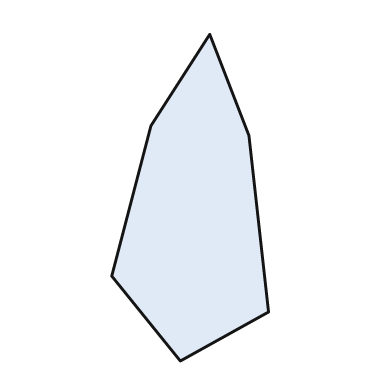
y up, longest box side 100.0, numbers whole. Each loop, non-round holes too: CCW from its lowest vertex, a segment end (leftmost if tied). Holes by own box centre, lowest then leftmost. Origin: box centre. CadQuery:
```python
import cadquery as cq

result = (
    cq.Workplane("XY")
    .moveTo(-3.0, -50.0)
    .lineTo(24.0, -35.0)
    .lineTo(18.0, 19.0)
    .lineTo(6.0, 50.0)
    .lineTo(-12.0, 22.0)
    .lineTo(-24.0, -24.0)
    .close()
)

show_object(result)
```